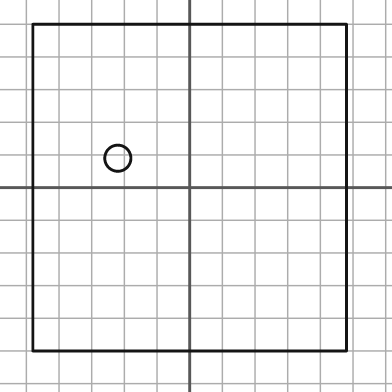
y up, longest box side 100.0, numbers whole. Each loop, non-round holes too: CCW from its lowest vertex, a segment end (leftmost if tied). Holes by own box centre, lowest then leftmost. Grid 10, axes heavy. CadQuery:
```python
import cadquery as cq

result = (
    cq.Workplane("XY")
    .moveTo(-48.0, -50.0)
    .lineTo(48.0, -50.0)
    .lineTo(48.0, 50.0)
    .lineTo(-48.0, 50.0)
    .close()
    .moveTo(-22.0, 9.0)
    .circle(4.0)
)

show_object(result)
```